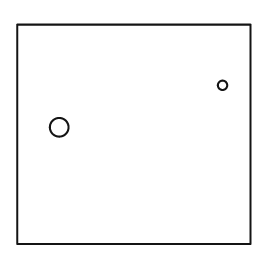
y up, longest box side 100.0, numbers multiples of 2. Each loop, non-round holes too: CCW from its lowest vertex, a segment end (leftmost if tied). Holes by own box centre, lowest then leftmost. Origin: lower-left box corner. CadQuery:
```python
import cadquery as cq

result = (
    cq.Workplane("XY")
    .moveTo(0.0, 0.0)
    .lineTo(100.0, 0.0)
    .lineTo(100.0, 94.0)
    .lineTo(0.0, 94.0)
    .close()
    .moveTo(18.0, 50.0)
    .circle(4.0)
    .moveTo(88.0, 68.0)
    .circle(2.0)
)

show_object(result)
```